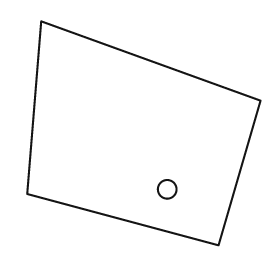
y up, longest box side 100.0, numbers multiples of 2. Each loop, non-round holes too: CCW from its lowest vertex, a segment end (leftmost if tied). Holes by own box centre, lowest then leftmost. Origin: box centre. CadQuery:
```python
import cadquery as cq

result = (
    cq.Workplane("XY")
    .moveTo(32.0, -48.0)
    .lineTo(50.0, 14.0)
    .lineTo(-44.0, 48.0)
    .lineTo(-50.0, -26.0)
    .close()
    .moveTo(10.0, -24.0)
    .circle(4.0)
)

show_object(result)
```